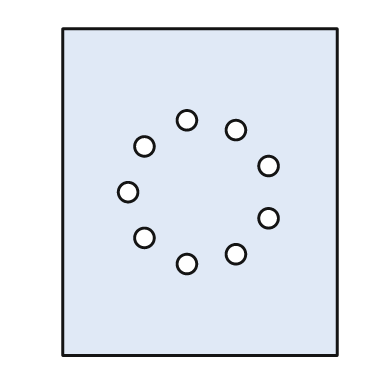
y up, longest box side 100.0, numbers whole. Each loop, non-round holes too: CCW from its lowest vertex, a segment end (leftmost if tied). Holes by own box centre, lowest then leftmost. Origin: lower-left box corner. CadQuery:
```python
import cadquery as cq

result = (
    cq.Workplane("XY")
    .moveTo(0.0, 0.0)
    .lineTo(84.0, 0.0)
    .lineTo(84.0, 100.0)
    .lineTo(0.0, 100.0)
    .close()
    .moveTo(38.0, 28.0)
    .circle(3.0)
    .moveTo(53.0, 31.0)
    .circle(3.0)
    .moveTo(25.0, 36.0)
    .circle(3.0)
    .moveTo(63.0, 42.0)
    .circle(3.0)
    .moveTo(20.0, 50.0)
    .circle(3.0)
    .moveTo(63.0, 58.0)
    .circle(3.0)
    .moveTo(25.0, 64.0)
    .circle(3.0)
    .moveTo(53.0, 69.0)
    .circle(3.0)
    .moveTo(38.0, 72.0)
    .circle(3.0)
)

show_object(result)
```